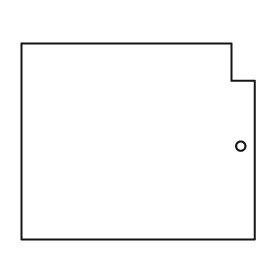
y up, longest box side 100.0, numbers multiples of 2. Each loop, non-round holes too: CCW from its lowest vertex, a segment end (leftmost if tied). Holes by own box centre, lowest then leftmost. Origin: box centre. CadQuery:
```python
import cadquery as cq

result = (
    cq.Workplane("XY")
    .moveTo(-50.0, -42.0)
    .lineTo(50.0, -42.0)
    .lineTo(50.0, 26.0)
    .lineTo(40.0, 26.0)
    .lineTo(40.0, 42.0)
    .lineTo(-50.0, 42.0)
    .close()
    .moveTo(44.0, -2.0)
    .circle(2.0)
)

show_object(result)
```